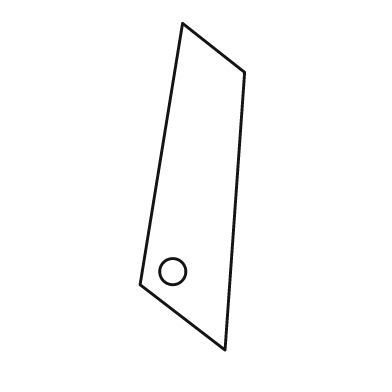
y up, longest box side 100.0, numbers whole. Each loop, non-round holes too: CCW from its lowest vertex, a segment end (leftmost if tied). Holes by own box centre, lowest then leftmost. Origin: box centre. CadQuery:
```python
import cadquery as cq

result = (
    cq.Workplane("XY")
    .moveTo(10.0, -50.0)
    .lineTo(16.0, 35.0)
    .lineTo(-3.0, 50.0)
    .lineTo(-16.0, -30.0)
    .close()
    .moveTo(-6.0, -26.0)
    .circle(4.0)
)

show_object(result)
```